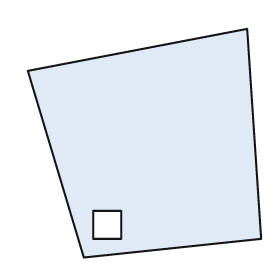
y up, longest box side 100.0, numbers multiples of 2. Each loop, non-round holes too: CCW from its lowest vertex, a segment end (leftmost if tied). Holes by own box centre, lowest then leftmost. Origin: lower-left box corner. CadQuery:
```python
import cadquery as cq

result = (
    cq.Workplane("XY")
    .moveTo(24.0, 0.0)
    .lineTo(100.0, 8.0)
    .lineTo(94.0, 98.0)
    .lineTo(0.0, 80.0)
    .close()
    .moveTo(28.0, 8.0)
    .lineTo(40.0, 8.0)
    .lineTo(40.0, 20.0)
    .lineTo(28.0, 20.0)
    .close()
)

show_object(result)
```